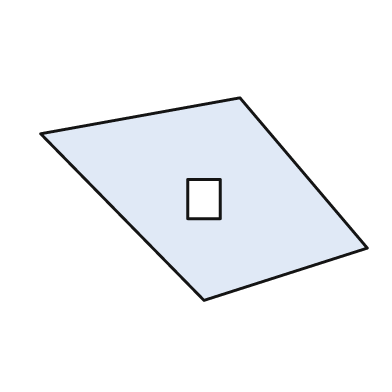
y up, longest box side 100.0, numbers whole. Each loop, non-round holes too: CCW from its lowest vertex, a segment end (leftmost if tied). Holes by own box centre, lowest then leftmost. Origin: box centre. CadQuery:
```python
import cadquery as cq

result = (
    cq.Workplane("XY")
    .moveTo(0.0, -31.0)
    .lineTo(50.0, -15.0)
    .lineTo(11.0, 31.0)
    .lineTo(-50.0, 20.0)
    .close()
    .moveTo(-5.0, -6.0)
    .lineTo(5.0, -6.0)
    .lineTo(5.0, 6.0)
    .lineTo(-5.0, 6.0)
    .close()
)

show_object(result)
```